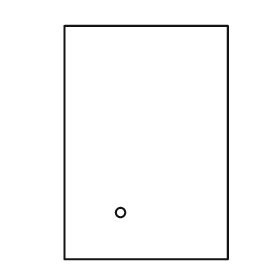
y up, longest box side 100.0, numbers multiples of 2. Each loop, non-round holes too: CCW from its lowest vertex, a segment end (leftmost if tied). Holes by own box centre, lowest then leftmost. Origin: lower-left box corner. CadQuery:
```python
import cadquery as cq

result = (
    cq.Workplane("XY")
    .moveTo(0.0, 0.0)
    .lineTo(70.0, 0.0)
    .lineTo(70.0, 100.0)
    .lineTo(0.0, 100.0)
    .close()
    .moveTo(24.0, 20.0)
    .circle(2.0)
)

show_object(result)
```